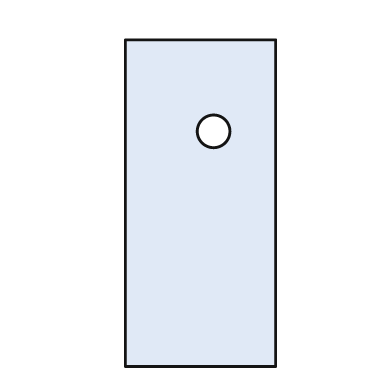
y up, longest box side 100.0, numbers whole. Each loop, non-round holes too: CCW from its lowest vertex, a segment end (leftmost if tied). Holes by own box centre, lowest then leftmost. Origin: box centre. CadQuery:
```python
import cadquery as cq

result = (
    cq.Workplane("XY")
    .moveTo(-23.0, -50.0)
    .lineTo(23.0, -50.0)
    .lineTo(23.0, 50.0)
    .lineTo(-23.0, 50.0)
    .close()
    .moveTo(4.0, 22.0)
    .circle(5.0)
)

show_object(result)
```